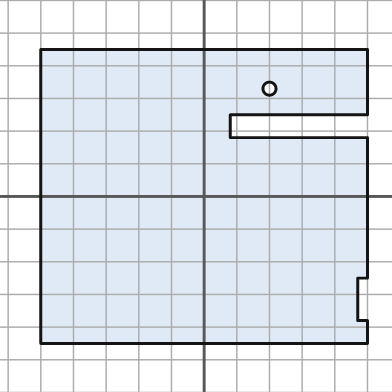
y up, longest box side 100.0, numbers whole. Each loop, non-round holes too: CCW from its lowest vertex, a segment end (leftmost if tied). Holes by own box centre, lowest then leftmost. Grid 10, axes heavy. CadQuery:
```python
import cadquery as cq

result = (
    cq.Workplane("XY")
    .moveTo(-50.0, -45.0)
    .lineTo(50.0, -45.0)
    .lineTo(50.0, -38.0)
    .lineTo(47.0, -38.0)
    .lineTo(47.0, -25.0)
    .lineTo(50.0, -25.0)
    .lineTo(50.0, 18.0)
    .lineTo(8.0, 18.0)
    .lineTo(8.0, 25.0)
    .lineTo(50.0, 25.0)
    .lineTo(50.0, 45.0)
    .lineTo(-50.0, 45.0)
    .close()
    .moveTo(20.0, 33.0)
    .circle(2.0)
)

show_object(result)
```